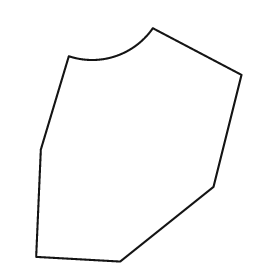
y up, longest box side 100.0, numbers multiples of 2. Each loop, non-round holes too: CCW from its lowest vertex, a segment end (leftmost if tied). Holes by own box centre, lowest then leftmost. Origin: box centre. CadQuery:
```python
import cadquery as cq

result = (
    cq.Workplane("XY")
    .moveTo(-8.0, -50.0)
    .lineTo(32.0, -18.0)
    .lineTo(44.0, 30.0)
    .lineTo(6.0, 50.0)
    .threePointArc((-10.0, 38.0), (-30.0, 38.0))
    .lineTo(-42.0, -2.0)
    .lineTo(-44.0, -48.0)
    .close()
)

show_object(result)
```